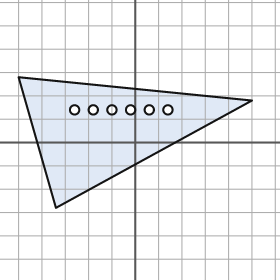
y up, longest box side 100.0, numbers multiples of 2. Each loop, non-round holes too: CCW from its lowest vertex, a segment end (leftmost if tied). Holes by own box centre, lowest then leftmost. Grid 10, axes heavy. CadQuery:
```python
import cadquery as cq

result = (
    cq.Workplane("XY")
    .moveTo(-34.0, -28.0)
    .lineTo(50.0, 18.0)
    .lineTo(-50.0, 28.0)
    .close()
    .moveTo(-26.0, 14.0)
    .circle(2.0)
    .moveTo(-18.0, 14.0)
    .circle(2.0)
    .moveTo(-10.0, 14.0)
    .circle(2.0)
    .moveTo(-2.0, 14.0)
    .circle(2.0)
    .moveTo(6.0, 14.0)
    .circle(2.0)
    .moveTo(14.0, 14.0)
    .circle(2.0)
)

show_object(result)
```